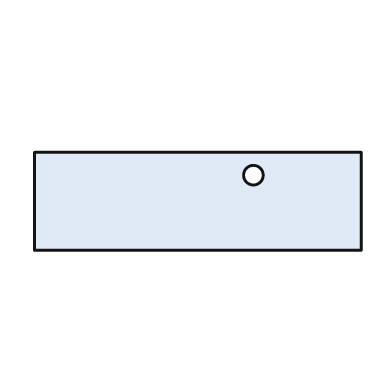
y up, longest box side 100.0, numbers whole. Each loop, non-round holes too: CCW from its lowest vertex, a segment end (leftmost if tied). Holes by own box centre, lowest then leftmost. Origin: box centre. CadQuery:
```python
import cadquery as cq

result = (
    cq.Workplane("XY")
    .moveTo(-50.0, -15.0)
    .lineTo(50.0, -15.0)
    .lineTo(50.0, 15.0)
    .lineTo(-50.0, 15.0)
    .close()
    .moveTo(17.0, 8.0)
    .circle(3.0)
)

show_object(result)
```